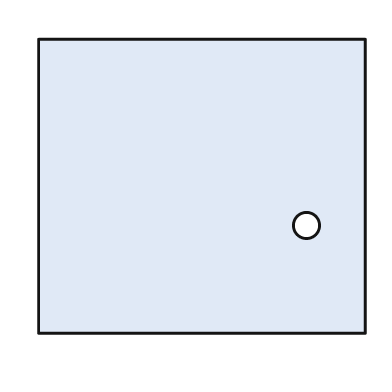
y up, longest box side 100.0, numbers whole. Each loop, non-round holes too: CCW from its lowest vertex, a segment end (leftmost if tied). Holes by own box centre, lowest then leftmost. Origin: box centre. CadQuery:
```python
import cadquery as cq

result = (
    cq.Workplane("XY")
    .moveTo(-50.0, -45.0)
    .lineTo(50.0, -45.0)
    .lineTo(50.0, 45.0)
    .lineTo(-50.0, 45.0)
    .close()
    .moveTo(32.0, -12.0)
    .circle(4.0)
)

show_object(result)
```